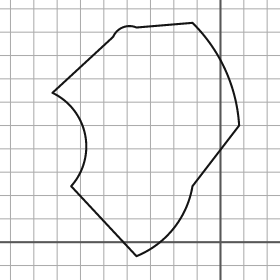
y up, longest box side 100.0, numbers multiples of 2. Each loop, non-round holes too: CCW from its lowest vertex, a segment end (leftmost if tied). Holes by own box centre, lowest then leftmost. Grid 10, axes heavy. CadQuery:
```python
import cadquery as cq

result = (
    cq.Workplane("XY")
    .moveTo(-36.0, -6.0)
    .threePointArc((-20.0, 6.0), (-12.0, 24.0))
    .lineTo(8.0, 50.0)
    .threePointArc((2.0, 74.0), (-12.0, 94.0))
    .lineTo(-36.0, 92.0)
    .threePointArc((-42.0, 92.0), (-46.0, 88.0))
    .lineTo(-72.0, 64.0)
    .threePointArc((-58.0, 46.0), (-64.0, 24.0))
    .close()
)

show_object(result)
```